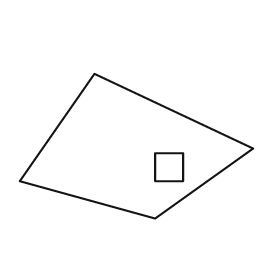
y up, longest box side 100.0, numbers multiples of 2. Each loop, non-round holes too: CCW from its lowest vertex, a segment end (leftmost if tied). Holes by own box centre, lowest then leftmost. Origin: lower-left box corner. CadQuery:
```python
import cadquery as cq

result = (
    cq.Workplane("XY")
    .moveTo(58.0, 0.0)
    .lineTo(100.0, 30.0)
    .lineTo(32.0, 62.0)
    .lineTo(0.0, 16.0)
    .close()
    .moveTo(58.0, 16.0)
    .lineTo(70.0, 16.0)
    .lineTo(70.0, 28.0)
    .lineTo(58.0, 28.0)
    .close()
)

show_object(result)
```